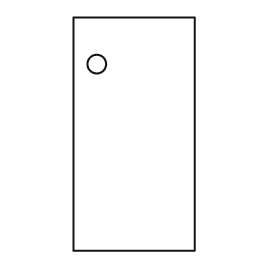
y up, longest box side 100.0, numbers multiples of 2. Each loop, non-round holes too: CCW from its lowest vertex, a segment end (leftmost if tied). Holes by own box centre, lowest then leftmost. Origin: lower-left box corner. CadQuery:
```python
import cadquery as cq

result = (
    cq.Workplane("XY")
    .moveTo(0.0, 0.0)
    .lineTo(52.0, 0.0)
    .lineTo(52.0, 100.0)
    .lineTo(0.0, 100.0)
    .close()
    .moveTo(10.0, 80.0)
    .circle(4.0)
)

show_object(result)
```